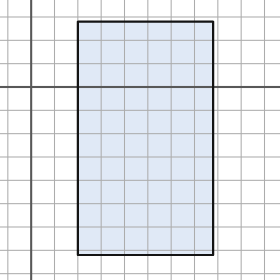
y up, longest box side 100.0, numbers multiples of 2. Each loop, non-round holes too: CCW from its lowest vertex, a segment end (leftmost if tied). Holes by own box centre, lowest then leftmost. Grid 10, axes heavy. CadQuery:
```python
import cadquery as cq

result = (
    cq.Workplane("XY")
    .moveTo(20.0, -72.0)
    .lineTo(78.0, -72.0)
    .lineTo(78.0, 28.0)
    .lineTo(20.0, 28.0)
    .close()
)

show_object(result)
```